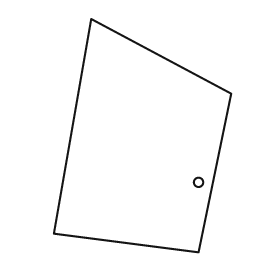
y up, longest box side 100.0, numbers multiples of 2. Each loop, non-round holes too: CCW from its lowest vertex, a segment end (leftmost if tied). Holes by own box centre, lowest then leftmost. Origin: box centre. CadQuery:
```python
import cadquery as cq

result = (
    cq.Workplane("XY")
    .moveTo(24.0, -50.0)
    .lineTo(38.0, 18.0)
    .lineTo(-22.0, 50.0)
    .lineTo(-38.0, -42.0)
    .close()
    .moveTo(24.0, -20.0)
    .circle(2.0)
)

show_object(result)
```